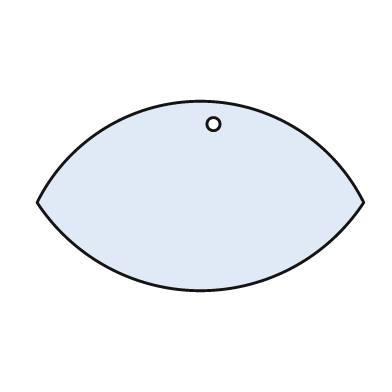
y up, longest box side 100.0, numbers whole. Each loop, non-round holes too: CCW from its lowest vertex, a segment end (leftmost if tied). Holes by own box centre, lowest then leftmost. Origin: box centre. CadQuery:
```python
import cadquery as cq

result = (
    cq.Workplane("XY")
    .moveTo(-50.0, -2.0)
    .threePointArc((0.0, -29.0), (50.0, -2.0))
    .threePointArc((0.0, 29.0), (-50.0, -2.0))
    .close()
    .moveTo(4.0, 22.0)
    .circle(2.0)
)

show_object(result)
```